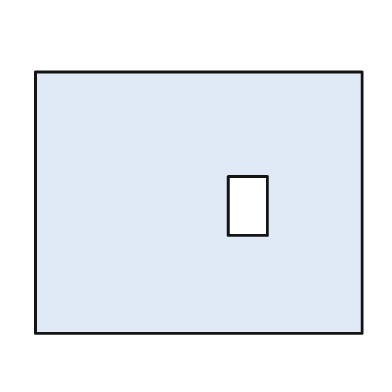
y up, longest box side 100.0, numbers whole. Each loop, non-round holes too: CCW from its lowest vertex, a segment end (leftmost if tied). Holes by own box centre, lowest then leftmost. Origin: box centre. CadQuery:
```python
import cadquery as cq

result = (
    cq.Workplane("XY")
    .moveTo(-50.0, -40.0)
    .lineTo(50.0, -40.0)
    .lineTo(50.0, 40.0)
    .lineTo(-50.0, 40.0)
    .close()
    .moveTo(9.0, -10.0)
    .lineTo(21.0, -10.0)
    .lineTo(21.0, 8.0)
    .lineTo(9.0, 8.0)
    .close()
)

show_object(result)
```